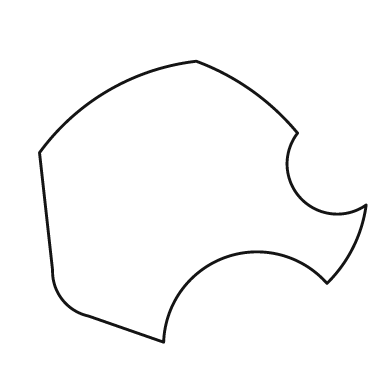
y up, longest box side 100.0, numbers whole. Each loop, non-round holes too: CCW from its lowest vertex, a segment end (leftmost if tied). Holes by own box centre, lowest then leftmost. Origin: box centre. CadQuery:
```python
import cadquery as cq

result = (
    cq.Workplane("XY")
    .moveTo(-12.0, -43.0)
    .threePointArc((7.0, -17.0), (38.0, -25.0))
    .threePointArc((46.0, -14.0), (50.0, -1.0))
    .threePointArc((30.0, 1.0), (29.0, 21.0))
    .threePointArc((15.0, 34.0), (-2.0, 43.0))
    .threePointArc((-29.0, 34.0), (-50.0, 15.0))
    .lineTo(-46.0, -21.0)
    .threePointArc((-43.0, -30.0), (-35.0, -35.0))
    .close()
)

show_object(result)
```